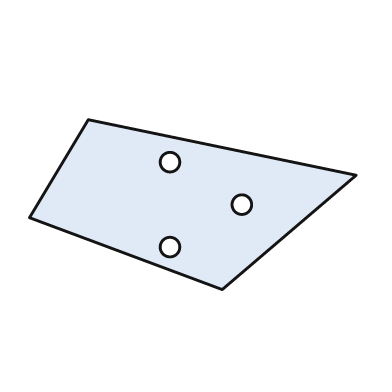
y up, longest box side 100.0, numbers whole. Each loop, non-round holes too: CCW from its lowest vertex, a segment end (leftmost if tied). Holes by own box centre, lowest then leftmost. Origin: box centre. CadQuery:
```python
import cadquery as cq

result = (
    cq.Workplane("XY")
    .moveTo(9.0, -26.0)
    .lineTo(50.0, 9.0)
    .lineTo(-32.0, 26.0)
    .lineTo(-50.0, -4.0)
    .close()
    .moveTo(-7.0, -13.0)
    .circle(3.0)
    .moveTo(15.0, 0.0)
    .circle(3.0)
    .moveTo(-7.0, 13.0)
    .circle(3.0)
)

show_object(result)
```